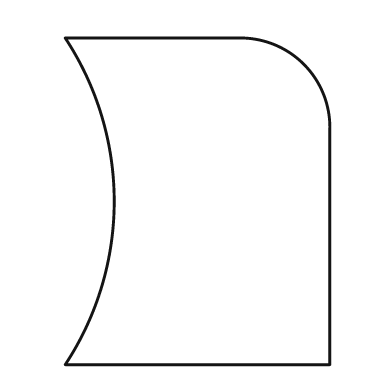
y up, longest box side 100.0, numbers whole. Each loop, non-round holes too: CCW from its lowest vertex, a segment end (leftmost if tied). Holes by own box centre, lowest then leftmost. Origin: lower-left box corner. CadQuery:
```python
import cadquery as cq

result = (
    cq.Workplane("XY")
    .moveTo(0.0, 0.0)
    .lineTo(81.0, 0.0)
    .lineTo(81.0, 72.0)
    .threePointArc((73.0, 92.0), (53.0, 100.0))
    .lineTo(0.0, 100.0)
    .threePointArc((15.0, 50.0), (0.0, 0.0))
    .close()
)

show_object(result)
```